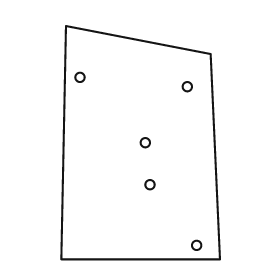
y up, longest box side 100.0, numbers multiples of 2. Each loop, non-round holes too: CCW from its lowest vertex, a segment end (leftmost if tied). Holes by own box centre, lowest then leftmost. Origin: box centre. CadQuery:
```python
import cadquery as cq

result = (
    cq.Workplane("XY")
    .moveTo(-34.0, -50.0)
    .lineTo(34.0, -50.0)
    .lineTo(30.0, 38.0)
    .lineTo(-32.0, 50.0)
    .close()
    .moveTo(24.0, -44.0)
    .circle(2.0)
    .moveTo(4.0, -18.0)
    .circle(2.0)
    .moveTo(2.0, 0.0)
    .circle(2.0)
    .moveTo(20.0, 24.0)
    .circle(2.0)
    .moveTo(-26.0, 28.0)
    .circle(2.0)
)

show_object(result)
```